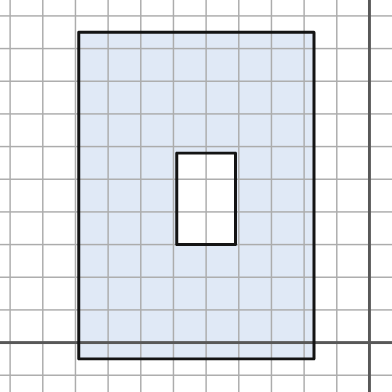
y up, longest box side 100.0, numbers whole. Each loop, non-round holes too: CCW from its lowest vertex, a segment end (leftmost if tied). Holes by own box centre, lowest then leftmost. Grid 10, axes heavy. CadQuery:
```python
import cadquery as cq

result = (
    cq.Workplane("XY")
    .moveTo(-89.0, -5.0)
    .lineTo(-17.0, -5.0)
    .lineTo(-17.0, 95.0)
    .lineTo(-89.0, 95.0)
    .close()
    .moveTo(-59.0, 30.0)
    .lineTo(-41.0, 30.0)
    .lineTo(-41.0, 58.0)
    .lineTo(-59.0, 58.0)
    .close()
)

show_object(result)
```